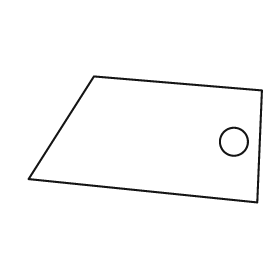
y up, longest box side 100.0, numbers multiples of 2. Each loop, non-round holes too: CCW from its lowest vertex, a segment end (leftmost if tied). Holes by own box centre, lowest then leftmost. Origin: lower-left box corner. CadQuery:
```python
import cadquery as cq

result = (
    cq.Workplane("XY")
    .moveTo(98.0, 0.0)
    .lineTo(100.0, 48.0)
    .lineTo(28.0, 54.0)
    .lineTo(0.0, 10.0)
    .close()
    .moveTo(88.0, 26.0)
    .circle(6.0)
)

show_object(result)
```